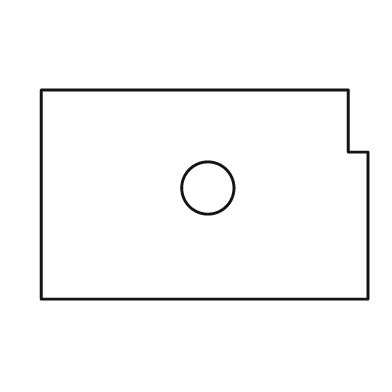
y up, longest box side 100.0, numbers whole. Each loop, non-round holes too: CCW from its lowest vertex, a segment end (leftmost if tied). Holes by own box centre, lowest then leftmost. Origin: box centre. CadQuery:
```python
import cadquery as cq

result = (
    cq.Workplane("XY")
    .moveTo(-50.0, -32.0)
    .lineTo(50.0, -32.0)
    .lineTo(50.0, 13.0)
    .lineTo(44.0, 13.0)
    .lineTo(44.0, 32.0)
    .lineTo(-50.0, 32.0)
    .close()
    .moveTo(1.0, 2.0)
    .circle(8.0)
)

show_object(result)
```